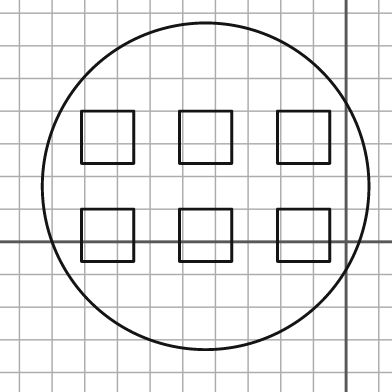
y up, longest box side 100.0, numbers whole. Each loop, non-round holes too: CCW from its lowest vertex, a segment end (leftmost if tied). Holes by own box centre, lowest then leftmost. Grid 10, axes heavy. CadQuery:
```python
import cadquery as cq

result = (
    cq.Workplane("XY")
    .moveTo(-43.0, 17.0)
    .circle(50.0)
    .moveTo(-81.0, -6.0)
    .lineTo(-65.0, -6.0)
    .lineTo(-65.0, 10.0)
    .lineTo(-81.0, 10.0)
    .close()
    .moveTo(-51.0, -6.0)
    .lineTo(-35.0, -6.0)
    .lineTo(-35.0, 10.0)
    .lineTo(-51.0, 10.0)
    .close()
    .moveTo(-21.0, -6.0)
    .lineTo(-5.0, -6.0)
    .lineTo(-5.0, 10.0)
    .lineTo(-21.0, 10.0)
    .close()
    .moveTo(-81.0, 24.0)
    .lineTo(-65.0, 24.0)
    .lineTo(-65.0, 40.0)
    .lineTo(-81.0, 40.0)
    .close()
    .moveTo(-51.0, 24.0)
    .lineTo(-35.0, 24.0)
    .lineTo(-35.0, 40.0)
    .lineTo(-51.0, 40.0)
    .close()
    .moveTo(-21.0, 24.0)
    .lineTo(-5.0, 24.0)
    .lineTo(-5.0, 40.0)
    .lineTo(-21.0, 40.0)
    .close()
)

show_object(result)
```